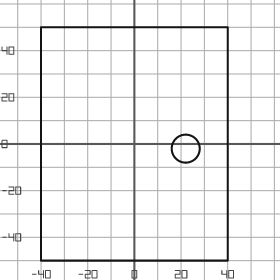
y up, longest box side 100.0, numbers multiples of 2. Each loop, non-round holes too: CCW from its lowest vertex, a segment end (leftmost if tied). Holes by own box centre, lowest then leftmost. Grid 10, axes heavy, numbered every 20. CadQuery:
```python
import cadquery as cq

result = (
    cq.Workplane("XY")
    .moveTo(-40.0, -50.0)
    .lineTo(40.0, -50.0)
    .lineTo(40.0, 50.0)
    .lineTo(-40.0, 50.0)
    .close()
    .moveTo(22.0, -2.0)
    .circle(6.0)
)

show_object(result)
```